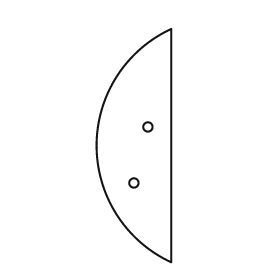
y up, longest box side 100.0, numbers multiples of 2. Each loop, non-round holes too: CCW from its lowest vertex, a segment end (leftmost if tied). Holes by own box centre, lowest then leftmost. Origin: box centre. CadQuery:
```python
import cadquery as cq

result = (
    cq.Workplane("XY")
    .moveTo(16.0, -50.0)
    .lineTo(16.0, 50.0)
    .threePointArc((-16.0, 0.0), (16.0, -50.0))
    .close()
    .moveTo(0.0, -16.0)
    .circle(2.0)
    .moveTo(6.0, 8.0)
    .circle(2.0)
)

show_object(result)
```